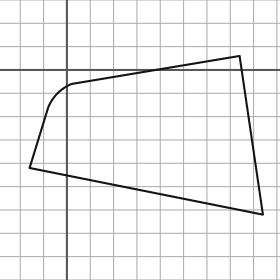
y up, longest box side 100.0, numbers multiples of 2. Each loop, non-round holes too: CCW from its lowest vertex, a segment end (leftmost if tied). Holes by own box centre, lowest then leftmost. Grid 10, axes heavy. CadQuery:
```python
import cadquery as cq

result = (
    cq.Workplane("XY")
    .moveTo(84.0, -62.0)
    .lineTo(74.0, 6.0)
    .lineTo(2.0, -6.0)
    .threePointArc((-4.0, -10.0), (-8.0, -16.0))
    .lineTo(-16.0, -42.0)
    .close()
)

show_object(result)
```